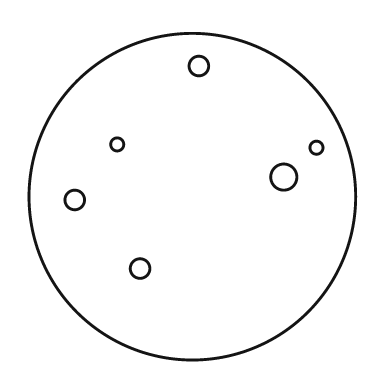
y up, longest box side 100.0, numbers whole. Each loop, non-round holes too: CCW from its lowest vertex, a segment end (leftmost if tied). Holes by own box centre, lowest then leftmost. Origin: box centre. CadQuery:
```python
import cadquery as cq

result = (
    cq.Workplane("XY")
    .moveTo(0.0, 0.0)
    .circle(50.0)
    .moveTo(-16.0, -22.0)
    .circle(3.0)
    .moveTo(-36.0, -1.0)
    .circle(3.0)
    .moveTo(28.0, 6.0)
    .circle(4.0)
    .moveTo(38.0, 15.0)
    .circle(2.0)
    .moveTo(-23.0, 16.0)
    .circle(2.0)
    .moveTo(2.0, 40.0)
    .circle(3.0)
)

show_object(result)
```